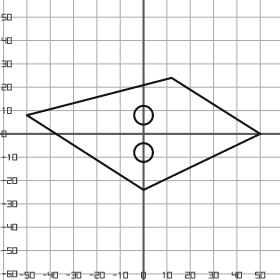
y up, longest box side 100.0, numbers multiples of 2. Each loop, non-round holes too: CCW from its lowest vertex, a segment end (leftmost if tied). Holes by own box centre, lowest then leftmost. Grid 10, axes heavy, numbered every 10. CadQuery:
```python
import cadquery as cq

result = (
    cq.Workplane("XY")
    .moveTo(0.0, -24.0)
    .lineTo(50.0, 0.0)
    .lineTo(12.0, 24.0)
    .lineTo(-50.0, 8.0)
    .close()
    .moveTo(0.0, -8.0)
    .circle(4.0)
    .moveTo(0.0, 8.0)
    .circle(4.0)
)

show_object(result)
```